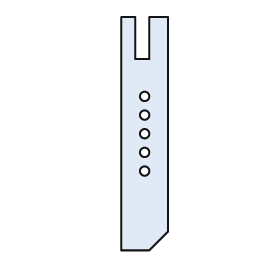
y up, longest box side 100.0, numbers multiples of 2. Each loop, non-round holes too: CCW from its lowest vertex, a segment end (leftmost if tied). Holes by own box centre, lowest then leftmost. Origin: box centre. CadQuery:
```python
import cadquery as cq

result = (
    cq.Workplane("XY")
    .moveTo(-10.0, -50.0)
    .lineTo(2.0, -50.0)
    .lineTo(10.0, -42.0)
    .lineTo(10.0, 50.0)
    .lineTo(2.0, 50.0)
    .lineTo(2.0, 32.0)
    .lineTo(-4.0, 32.0)
    .lineTo(-4.0, 50.0)
    .lineTo(-10.0, 50.0)
    .close()
    .moveTo(0.0, -16.0)
    .circle(2.0)
    .moveTo(0.0, -8.0)
    .circle(2.0)
    .moveTo(0.0, 0.0)
    .circle(2.0)
    .moveTo(0.0, 8.0)
    .circle(2.0)
    .moveTo(0.0, 16.0)
    .circle(2.0)
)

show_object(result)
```